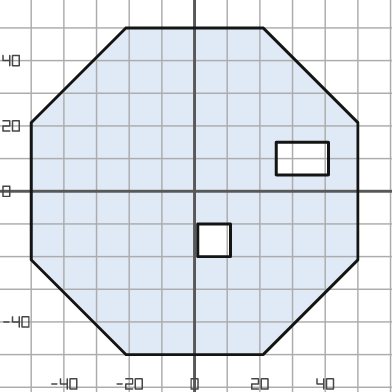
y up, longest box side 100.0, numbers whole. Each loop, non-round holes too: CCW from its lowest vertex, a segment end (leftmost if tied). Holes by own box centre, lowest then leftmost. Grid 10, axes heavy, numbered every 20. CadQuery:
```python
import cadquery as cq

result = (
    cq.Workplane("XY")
    .moveTo(-21.0, -50.0)
    .lineTo(21.0, -50.0)
    .lineTo(50.0, -21.0)
    .lineTo(50.0, 21.0)
    .lineTo(21.0, 50.0)
    .lineTo(-21.0, 50.0)
    .lineTo(-50.0, 21.0)
    .lineTo(-50.0, -21.0)
    .close()
    .moveTo(1.0, -20.0)
    .lineTo(11.0, -20.0)
    .lineTo(11.0, -10.0)
    .lineTo(1.0, -10.0)
    .close()
    .moveTo(25.0, 5.0)
    .lineTo(41.0, 5.0)
    .lineTo(41.0, 15.0)
    .lineTo(25.0, 15.0)
    .close()
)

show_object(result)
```